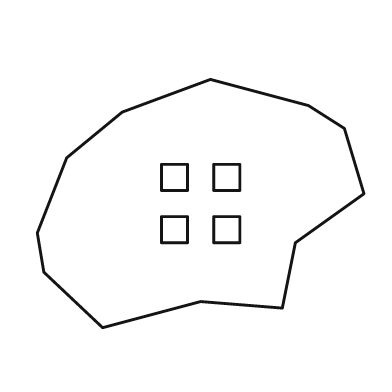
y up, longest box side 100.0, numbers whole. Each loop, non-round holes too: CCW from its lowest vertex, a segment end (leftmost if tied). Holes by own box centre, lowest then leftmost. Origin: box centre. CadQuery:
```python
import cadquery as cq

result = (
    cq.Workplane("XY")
    .moveTo(-30.0, -38.0)
    .lineTo(0.0, -30.0)
    .lineTo(25.0, -32.0)
    .lineTo(29.0, -12.0)
    .lineTo(50.0, 3.0)
    .lineTo(44.0, 23.0)
    .lineTo(33.0, 30.0)
    .lineTo(3.0, 38.0)
    .lineTo(-24.0, 28.0)
    .lineTo(-41.0, 14.0)
    .lineTo(-50.0, -9.0)
    .lineTo(-48.0, -21.0)
    .close()
    .moveTo(-12.0, -12.0)
    .lineTo(-4.0, -12.0)
    .lineTo(-4.0, -4.0)
    .lineTo(-12.0, -4.0)
    .close()
    .moveTo(4.0, -12.0)
    .lineTo(12.0, -12.0)
    .lineTo(12.0, -4.0)
    .lineTo(4.0, -4.0)
    .close()
    .moveTo(-12.0, 4.0)
    .lineTo(-4.0, 4.0)
    .lineTo(-4.0, 12.0)
    .lineTo(-12.0, 12.0)
    .close()
    .moveTo(4.0, 4.0)
    .lineTo(12.0, 4.0)
    .lineTo(12.0, 12.0)
    .lineTo(4.0, 12.0)
    .close()
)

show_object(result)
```